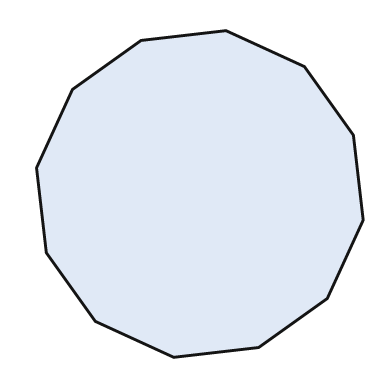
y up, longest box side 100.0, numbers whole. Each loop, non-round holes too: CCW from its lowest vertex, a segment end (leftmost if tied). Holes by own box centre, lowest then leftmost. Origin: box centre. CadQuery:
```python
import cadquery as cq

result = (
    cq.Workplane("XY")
    .moveTo(-8.0, -50.0)
    .lineTo(18.0, -47.0)
    .lineTo(39.0, -32.0)
    .lineTo(50.0, -8.0)
    .lineTo(47.0, 18.0)
    .lineTo(32.0, 39.0)
    .lineTo(8.0, 50.0)
    .lineTo(-18.0, 47.0)
    .lineTo(-39.0, 32.0)
    .lineTo(-50.0, 8.0)
    .lineTo(-47.0, -18.0)
    .lineTo(-32.0, -39.0)
    .close()
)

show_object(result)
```